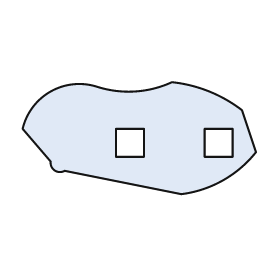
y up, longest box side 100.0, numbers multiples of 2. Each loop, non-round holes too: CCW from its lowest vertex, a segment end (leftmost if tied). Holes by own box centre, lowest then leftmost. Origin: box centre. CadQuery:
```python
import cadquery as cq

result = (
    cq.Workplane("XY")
    .moveTo(18.0, -24.0)
    .threePointArc((36.0, -18.0), (50.0, -6.0))
    .lineTo(44.0, 12.0)
    .threePointArc((30.0, 20.0), (14.0, 24.0))
    .threePointArc((-2.0, 20.0), (-18.0, 22.0))
    .threePointArc((-38.0, 20.0), (-50.0, 4.0))
    .lineTo(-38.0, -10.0)
    .threePointArc((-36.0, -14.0), (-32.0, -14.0))
    .close()
    .moveTo(-10.0, -8.0)
    .lineTo(2.0, -8.0)
    .lineTo(2.0, 4.0)
    .lineTo(-10.0, 4.0)
    .close()
    .moveTo(28.0, -8.0)
    .lineTo(40.0, -8.0)
    .lineTo(40.0, 4.0)
    .lineTo(28.0, 4.0)
    .close()
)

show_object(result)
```